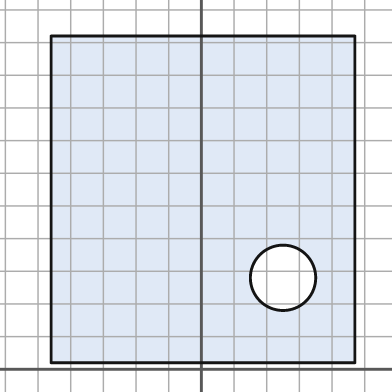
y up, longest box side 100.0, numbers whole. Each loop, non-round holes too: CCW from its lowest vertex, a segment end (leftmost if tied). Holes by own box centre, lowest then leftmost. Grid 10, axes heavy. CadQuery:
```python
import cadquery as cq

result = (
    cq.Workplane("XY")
    .moveTo(-46.0, 2.0)
    .lineTo(47.0, 2.0)
    .lineTo(47.0, 102.0)
    .lineTo(-46.0, 102.0)
    .close()
    .moveTo(25.0, 28.0)
    .circle(10.0)
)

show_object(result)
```